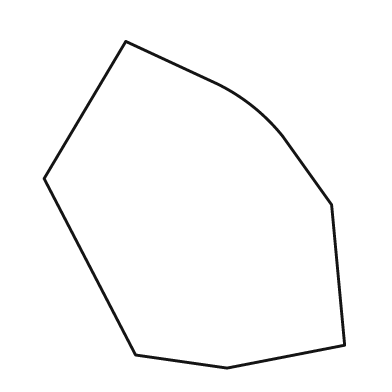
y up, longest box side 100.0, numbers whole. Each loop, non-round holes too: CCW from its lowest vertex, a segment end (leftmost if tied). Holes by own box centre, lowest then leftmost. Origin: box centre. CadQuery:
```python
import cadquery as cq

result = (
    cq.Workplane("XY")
    .moveTo(10.0, -50.0)
    .lineTo(46.0, -43.0)
    .lineTo(42.0, 0.0)
    .lineTo(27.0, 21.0)
    .threePointArc((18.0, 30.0), (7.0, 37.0))
    .lineTo(-21.0, 50.0)
    .lineTo(-46.0, 8.0)
    .lineTo(-18.0, -46.0)
    .close()
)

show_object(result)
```